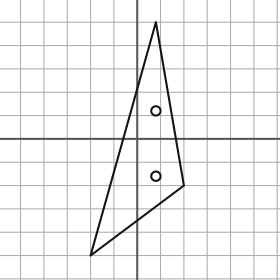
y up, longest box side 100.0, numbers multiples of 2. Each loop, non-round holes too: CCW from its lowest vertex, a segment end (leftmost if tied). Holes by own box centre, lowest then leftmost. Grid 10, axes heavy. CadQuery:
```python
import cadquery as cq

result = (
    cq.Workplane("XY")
    .moveTo(-20.0, -50.0)
    .lineTo(20.0, -20.0)
    .lineTo(8.0, 50.0)
    .close()
    .moveTo(8.0, -16.0)
    .circle(2.0)
    .moveTo(8.0, 12.0)
    .circle(2.0)
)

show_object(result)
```